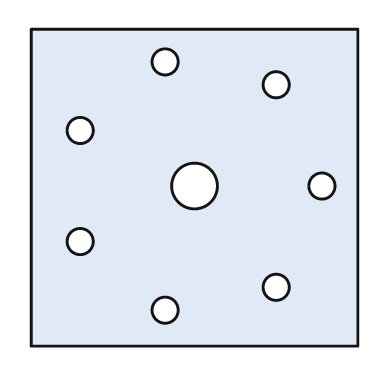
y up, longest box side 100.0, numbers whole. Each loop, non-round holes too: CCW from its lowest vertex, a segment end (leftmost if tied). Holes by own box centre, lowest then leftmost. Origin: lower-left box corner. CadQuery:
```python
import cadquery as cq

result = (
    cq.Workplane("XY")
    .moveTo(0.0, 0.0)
    .lineTo(100.0, 0.0)
    .lineTo(100.0, 97.0)
    .lineTo(0.0, 97.0)
    .close()
    .moveTo(41.0, 11.0)
    .circle(4.0)
    .moveTo(75.0, 18.0)
    .circle(4.0)
    .moveTo(15.0, 32.0)
    .circle(4.0)
    .moveTo(50.0, 49.0)
    .circle(7.0)
    .moveTo(89.0, 49.0)
    .circle(4.0)
    .moveTo(15.0, 66.0)
    .circle(4.0)
    .moveTo(75.0, 80.0)
    .circle(4.0)
    .moveTo(41.0, 87.0)
    .circle(4.0)
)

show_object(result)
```